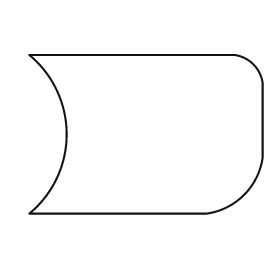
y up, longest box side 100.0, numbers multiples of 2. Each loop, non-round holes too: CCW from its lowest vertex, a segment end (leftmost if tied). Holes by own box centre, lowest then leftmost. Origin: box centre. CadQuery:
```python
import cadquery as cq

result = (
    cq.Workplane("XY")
    .moveTo(-50.0, -34.0)
    .lineTo(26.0, -34.0)
    .threePointArc((42.0, -26.0), (50.0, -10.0))
    .lineTo(50.0, 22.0)
    .threePointArc((46.0, 30.0), (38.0, 34.0))
    .lineTo(-50.0, 34.0)
    .threePointArc((-34.0, 0.0), (-50.0, -34.0))
    .close()
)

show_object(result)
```